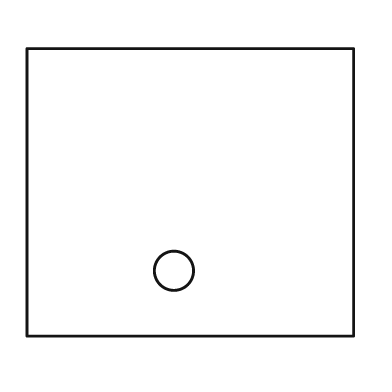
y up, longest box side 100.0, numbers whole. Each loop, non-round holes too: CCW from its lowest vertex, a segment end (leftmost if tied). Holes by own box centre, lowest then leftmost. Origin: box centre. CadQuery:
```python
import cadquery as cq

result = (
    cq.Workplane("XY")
    .moveTo(-50.0, -44.0)
    .lineTo(50.0, -44.0)
    .lineTo(50.0, 44.0)
    .lineTo(-50.0, 44.0)
    .close()
    .moveTo(-5.0, -24.0)
    .circle(6.0)
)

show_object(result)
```